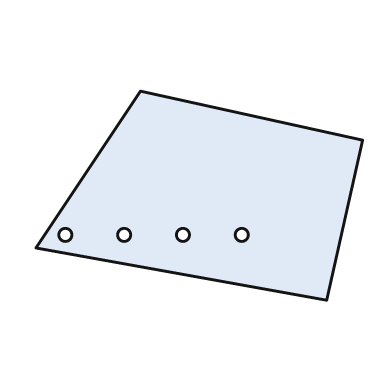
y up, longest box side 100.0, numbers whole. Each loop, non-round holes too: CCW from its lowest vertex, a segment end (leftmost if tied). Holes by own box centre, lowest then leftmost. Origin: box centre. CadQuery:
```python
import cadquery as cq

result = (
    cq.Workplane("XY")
    .moveTo(39.0, -32.0)
    .lineTo(50.0, 17.0)
    .lineTo(-18.0, 32.0)
    .lineTo(-50.0, -16.0)
    .close()
    .moveTo(-41.0, -12.0)
    .circle(2.0)
    .moveTo(-23.0, -12.0)
    .circle(2.0)
    .moveTo(-5.0, -12.0)
    .circle(2.0)
    .moveTo(13.0, -12.0)
    .circle(2.0)
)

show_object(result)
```